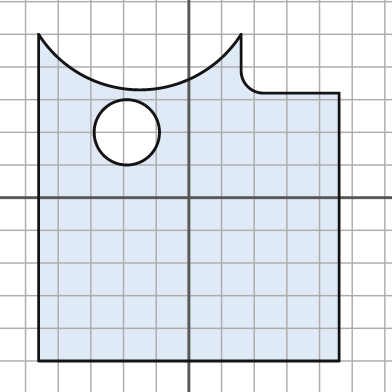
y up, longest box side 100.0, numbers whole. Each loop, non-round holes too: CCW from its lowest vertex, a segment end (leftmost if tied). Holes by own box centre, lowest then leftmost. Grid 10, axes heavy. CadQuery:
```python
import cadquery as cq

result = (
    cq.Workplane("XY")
    .moveTo(-46.0, -50.0)
    .lineTo(46.0, -50.0)
    .lineTo(46.0, 32.0)
    .lineTo(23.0, 32.0)
    .threePointArc((18.0, 34.0), (16.0, 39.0))
    .lineTo(16.0, 50.0)
    .threePointArc((-15.0, 33.0), (-46.0, 50.0))
    .close()
    .moveTo(-19.0, 20.0)
    .circle(10.0)
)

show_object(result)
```